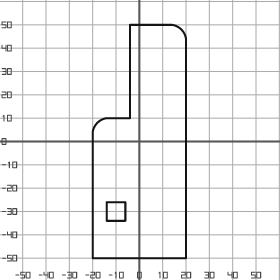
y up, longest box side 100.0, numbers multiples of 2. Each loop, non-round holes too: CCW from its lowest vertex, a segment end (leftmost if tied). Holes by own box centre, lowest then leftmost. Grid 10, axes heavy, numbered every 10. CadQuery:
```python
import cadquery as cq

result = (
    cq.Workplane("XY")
    .moveTo(-20.0, -50.0)
    .lineTo(20.0, -50.0)
    .lineTo(20.0, 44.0)
    .threePointArc((18.0, 48.0), (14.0, 50.0))
    .lineTo(-4.0, 50.0)
    .lineTo(-4.0, 10.0)
    .lineTo(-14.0, 10.0)
    .threePointArc((-18.0, 8.0), (-20.0, 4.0))
    .close()
    .moveTo(-14.0, -34.0)
    .lineTo(-6.0, -34.0)
    .lineTo(-6.0, -26.0)
    .lineTo(-14.0, -26.0)
    .close()
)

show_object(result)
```